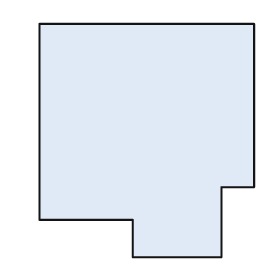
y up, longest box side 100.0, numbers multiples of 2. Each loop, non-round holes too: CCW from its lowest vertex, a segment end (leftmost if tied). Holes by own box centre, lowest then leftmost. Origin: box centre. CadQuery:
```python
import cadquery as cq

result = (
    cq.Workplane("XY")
    .moveTo(-6.0, -50.0)
    .lineTo(32.0, -50.0)
    .lineTo(32.0, -20.0)
    .lineTo(46.0, -20.0)
    .lineTo(46.0, 50.0)
    .lineTo(-46.0, 50.0)
    .lineTo(-46.0, -34.0)
    .lineTo(-6.0, -34.0)
    .close()
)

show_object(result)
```